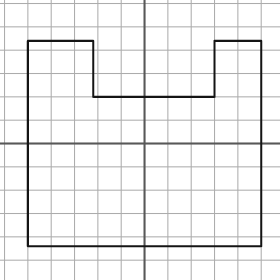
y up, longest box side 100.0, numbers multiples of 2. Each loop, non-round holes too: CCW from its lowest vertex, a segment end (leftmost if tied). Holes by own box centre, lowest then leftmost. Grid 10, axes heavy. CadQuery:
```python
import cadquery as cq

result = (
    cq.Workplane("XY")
    .moveTo(-50.0, -44.0)
    .lineTo(50.0, -44.0)
    .lineTo(50.0, 44.0)
    .lineTo(30.0, 44.0)
    .lineTo(30.0, 20.0)
    .lineTo(-22.0, 20.0)
    .lineTo(-22.0, 44.0)
    .lineTo(-50.0, 44.0)
    .close()
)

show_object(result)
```